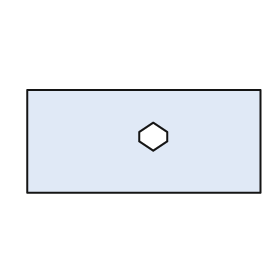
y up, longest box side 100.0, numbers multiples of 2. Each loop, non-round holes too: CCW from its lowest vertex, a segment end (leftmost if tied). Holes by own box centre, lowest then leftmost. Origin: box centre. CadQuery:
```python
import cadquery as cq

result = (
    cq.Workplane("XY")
    .moveTo(-50.0, -22.0)
    .lineTo(50.0, -22.0)
    .lineTo(50.0, 22.0)
    .lineTo(-50.0, 22.0)
    .close()
    .moveTo(4.0, -4.0)
    .lineTo(10.0, 0.0)
    .lineTo(10.0, 4.0)
    .lineTo(4.0, 8.0)
    .lineTo(-2.0, 4.0)
    .lineTo(-2.0, 0.0)
    .close()
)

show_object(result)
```